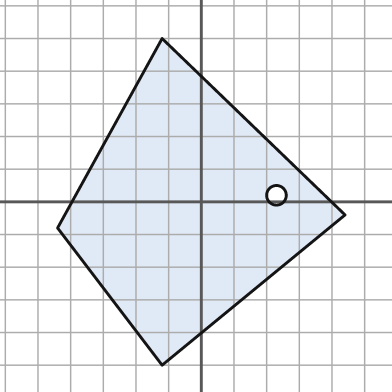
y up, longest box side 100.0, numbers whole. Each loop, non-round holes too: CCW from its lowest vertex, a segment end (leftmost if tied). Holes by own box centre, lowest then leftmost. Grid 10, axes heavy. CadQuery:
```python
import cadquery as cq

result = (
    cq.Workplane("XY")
    .moveTo(-12.0, -50.0)
    .lineTo(44.0, -4.0)
    .lineTo(-12.0, 50.0)
    .lineTo(-44.0, -8.0)
    .close()
    .moveTo(23.0, 2.0)
    .circle(3.0)
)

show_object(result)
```